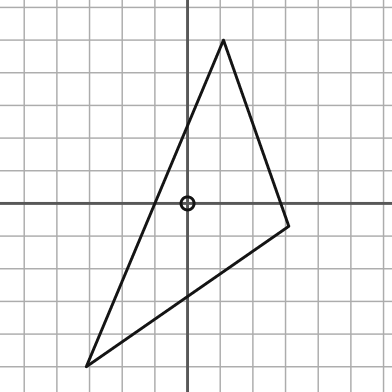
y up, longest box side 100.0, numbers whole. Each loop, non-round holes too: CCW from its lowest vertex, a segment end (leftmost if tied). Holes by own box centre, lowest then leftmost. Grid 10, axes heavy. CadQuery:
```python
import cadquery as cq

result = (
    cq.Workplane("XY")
    .moveTo(-31.0, -50.0)
    .lineTo(31.0, -7.0)
    .lineTo(11.0, 50.0)
    .close()
    .moveTo(0.0, 0.0)
    .circle(2.0)
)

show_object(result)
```